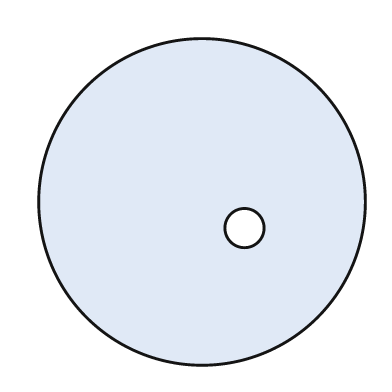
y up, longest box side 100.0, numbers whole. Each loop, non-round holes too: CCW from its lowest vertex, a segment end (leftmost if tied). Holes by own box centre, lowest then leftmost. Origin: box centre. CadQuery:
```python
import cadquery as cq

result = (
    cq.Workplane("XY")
    .moveTo(0.0, 0.0)
    .circle(50.0)
    .moveTo(13.0, -8.0)
    .circle(6.0)
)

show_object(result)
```